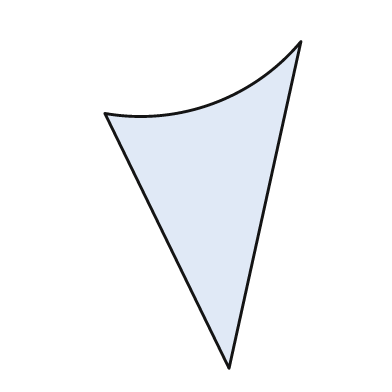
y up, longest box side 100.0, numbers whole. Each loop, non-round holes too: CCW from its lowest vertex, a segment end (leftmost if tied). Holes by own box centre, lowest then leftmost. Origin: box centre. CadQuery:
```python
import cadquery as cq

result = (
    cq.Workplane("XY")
    .moveTo(8.0, -50.0)
    .lineTo(30.0, 50.0)
    .threePointArc((3.0, 31.0), (-30.0, 28.0))
    .close()
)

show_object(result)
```